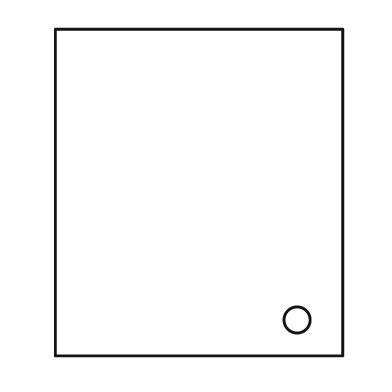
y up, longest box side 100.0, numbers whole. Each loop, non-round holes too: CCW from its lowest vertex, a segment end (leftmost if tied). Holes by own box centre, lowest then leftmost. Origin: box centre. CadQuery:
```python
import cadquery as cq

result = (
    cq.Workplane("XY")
    .moveTo(-44.0, -50.0)
    .lineTo(44.0, -50.0)
    .lineTo(44.0, 50.0)
    .lineTo(-44.0, 50.0)
    .close()
    .moveTo(30.0, -39.0)
    .circle(4.0)
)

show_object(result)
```